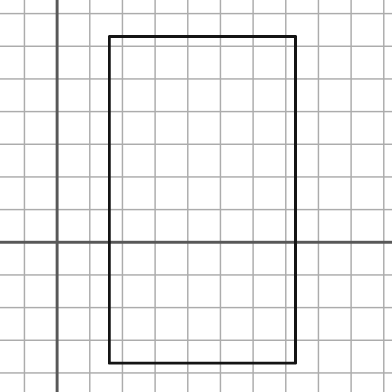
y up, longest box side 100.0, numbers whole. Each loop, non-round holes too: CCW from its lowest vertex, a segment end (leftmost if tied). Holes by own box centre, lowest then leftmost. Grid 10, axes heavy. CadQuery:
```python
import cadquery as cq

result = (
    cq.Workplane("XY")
    .moveTo(16.0, -37.0)
    .lineTo(73.0, -37.0)
    .lineTo(73.0, 63.0)
    .lineTo(16.0, 63.0)
    .close()
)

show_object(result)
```